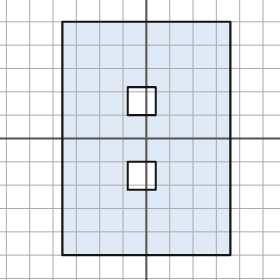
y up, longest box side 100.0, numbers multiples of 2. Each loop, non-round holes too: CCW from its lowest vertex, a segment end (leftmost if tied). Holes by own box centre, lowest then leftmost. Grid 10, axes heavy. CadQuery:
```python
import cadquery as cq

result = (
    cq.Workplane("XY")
    .moveTo(-36.0, -50.0)
    .lineTo(36.0, -50.0)
    .lineTo(36.0, 50.0)
    .lineTo(-36.0, 50.0)
    .close()
    .moveTo(-8.0, -22.0)
    .lineTo(4.0, -22.0)
    .lineTo(4.0, -10.0)
    .lineTo(-8.0, -10.0)
    .close()
    .moveTo(-8.0, 10.0)
    .lineTo(4.0, 10.0)
    .lineTo(4.0, 22.0)
    .lineTo(-8.0, 22.0)
    .close()
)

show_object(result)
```